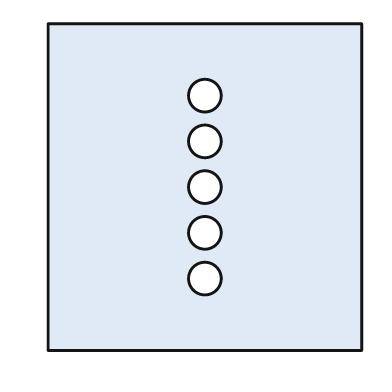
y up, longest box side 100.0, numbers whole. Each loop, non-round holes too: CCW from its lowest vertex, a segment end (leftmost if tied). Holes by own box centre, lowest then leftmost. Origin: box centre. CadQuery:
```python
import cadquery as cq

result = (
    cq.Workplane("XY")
    .moveTo(-48.0, -50.0)
    .lineTo(48.0, -50.0)
    .lineTo(48.0, 50.0)
    .lineTo(-48.0, 50.0)
    .close()
    .moveTo(0.0, -28.0)
    .circle(5.0)
    .moveTo(0.0, -14.0)
    .circle(5.0)
    .moveTo(0.0, 0.0)
    .circle(5.0)
    .moveTo(0.0, 14.0)
    .circle(5.0)
    .moveTo(0.0, 28.0)
    .circle(5.0)
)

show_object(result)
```